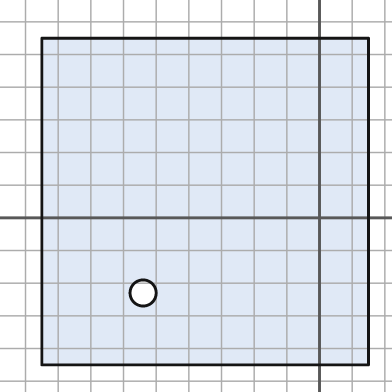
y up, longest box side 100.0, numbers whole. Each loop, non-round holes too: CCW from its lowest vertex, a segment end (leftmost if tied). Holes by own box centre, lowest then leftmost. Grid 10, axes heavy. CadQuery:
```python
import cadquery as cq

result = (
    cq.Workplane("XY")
    .moveTo(-85.0, -45.0)
    .lineTo(15.0, -45.0)
    .lineTo(15.0, 55.0)
    .lineTo(-85.0, 55.0)
    .close()
    .moveTo(-54.0, -23.0)
    .circle(4.0)
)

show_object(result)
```